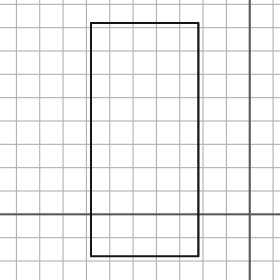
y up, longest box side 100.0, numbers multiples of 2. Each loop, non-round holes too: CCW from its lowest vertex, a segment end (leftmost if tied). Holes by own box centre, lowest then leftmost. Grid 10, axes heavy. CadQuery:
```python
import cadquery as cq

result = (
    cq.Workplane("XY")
    .moveTo(-68.0, -18.0)
    .lineTo(-22.0, -18.0)
    .lineTo(-22.0, 82.0)
    .lineTo(-68.0, 82.0)
    .close()
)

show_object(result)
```